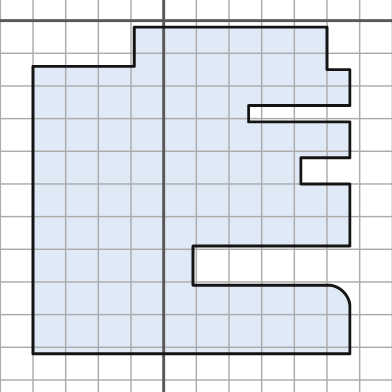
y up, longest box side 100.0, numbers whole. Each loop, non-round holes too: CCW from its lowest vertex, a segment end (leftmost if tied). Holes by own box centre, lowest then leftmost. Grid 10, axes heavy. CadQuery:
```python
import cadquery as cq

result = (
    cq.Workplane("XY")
    .moveTo(-40.0, -102.0)
    .lineTo(57.0, -102.0)
    .lineTo(57.0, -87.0)
    .threePointArc((55.0, -83.0), (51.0, -81.0))
    .lineTo(9.0, -81.0)
    .lineTo(9.0, -69.0)
    .lineTo(57.0, -69.0)
    .lineTo(57.0, -50.0)
    .lineTo(42.0, -50.0)
    .lineTo(42.0, -42.0)
    .lineTo(57.0, -42.0)
    .lineTo(57.0, -31.0)
    .lineTo(26.0, -31.0)
    .lineTo(26.0, -26.0)
    .lineTo(57.0, -26.0)
    .lineTo(57.0, -15.0)
    .lineTo(50.0, -15.0)
    .lineTo(50.0, -2.0)
    .lineTo(-9.0, -2.0)
    .lineTo(-9.0, -14.0)
    .lineTo(-40.0, -14.0)
    .close()
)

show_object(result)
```